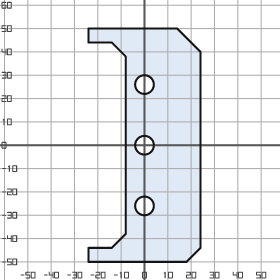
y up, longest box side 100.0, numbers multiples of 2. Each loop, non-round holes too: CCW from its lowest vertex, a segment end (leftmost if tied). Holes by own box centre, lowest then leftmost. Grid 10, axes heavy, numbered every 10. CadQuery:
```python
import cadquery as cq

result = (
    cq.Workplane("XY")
    .moveTo(-24.0, -50.0)
    .lineTo(18.0, -50.0)
    .lineTo(24.0, -44.0)
    .lineTo(24.0, 40.0)
    .lineTo(14.0, 50.0)
    .lineTo(-24.0, 50.0)
    .lineTo(-24.0, 44.0)
    .lineTo(-14.0, 44.0)
    .lineTo(-8.0, 38.0)
    .lineTo(-8.0, -38.0)
    .lineTo(-14.0, -44.0)
    .lineTo(-24.0, -44.0)
    .close()
    .moveTo(0.0, -26.0)
    .circle(4.0)
    .moveTo(0.0, 0.0)
    .circle(4.0)
    .moveTo(0.0, 26.0)
    .circle(4.0)
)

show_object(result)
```